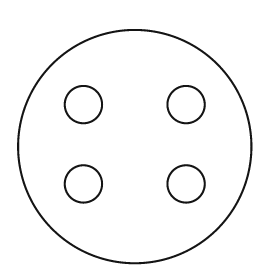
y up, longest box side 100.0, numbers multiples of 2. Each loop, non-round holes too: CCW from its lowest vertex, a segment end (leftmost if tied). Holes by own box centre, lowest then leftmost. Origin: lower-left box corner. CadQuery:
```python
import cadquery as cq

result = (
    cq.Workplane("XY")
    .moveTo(50.0, 50.0)
    .circle(50.0)
    .moveTo(28.0, 34.0)
    .circle(8.0)
    .moveTo(72.0, 34.0)
    .circle(8.0)
    .moveTo(28.0, 68.0)
    .circle(8.0)
    .moveTo(72.0, 68.0)
    .circle(8.0)
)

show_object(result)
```